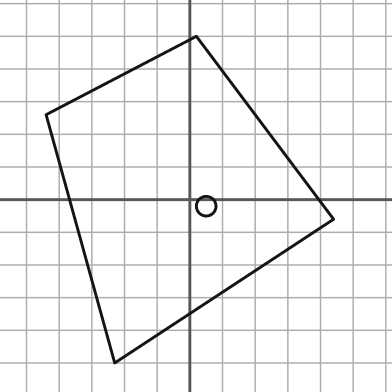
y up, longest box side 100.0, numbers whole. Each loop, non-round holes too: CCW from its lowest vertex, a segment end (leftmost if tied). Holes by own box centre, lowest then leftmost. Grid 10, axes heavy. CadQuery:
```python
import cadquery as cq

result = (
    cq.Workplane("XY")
    .moveTo(-23.0, -50.0)
    .lineTo(44.0, -6.0)
    .lineTo(2.0, 50.0)
    .lineTo(-44.0, 26.0)
    .close()
    .moveTo(5.0, -2.0)
    .circle(3.0)
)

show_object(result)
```